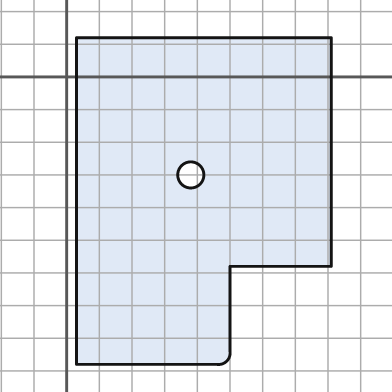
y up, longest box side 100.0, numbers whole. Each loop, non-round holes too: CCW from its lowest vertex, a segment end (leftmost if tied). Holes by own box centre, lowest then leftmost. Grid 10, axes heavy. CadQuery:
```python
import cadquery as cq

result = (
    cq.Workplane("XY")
    .moveTo(3.0, -88.0)
    .lineTo(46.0, -88.0)
    .threePointArc((49.0, -87.0), (50.0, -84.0))
    .lineTo(50.0, -58.0)
    .lineTo(81.0, -58.0)
    .lineTo(81.0, 12.0)
    .lineTo(3.0, 12.0)
    .close()
    .moveTo(38.0, -30.0)
    .circle(4.0)
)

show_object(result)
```